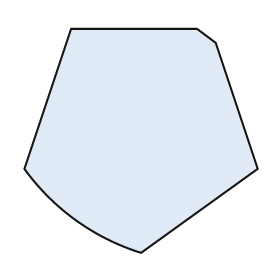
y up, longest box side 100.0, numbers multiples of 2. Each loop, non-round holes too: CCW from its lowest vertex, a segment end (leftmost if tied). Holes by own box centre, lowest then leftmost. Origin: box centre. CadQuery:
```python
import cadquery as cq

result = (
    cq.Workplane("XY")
    .moveTo(0.0, -48.0)
    .lineTo(50.0, -12.0)
    .lineTo(32.0, 42.0)
    .lineTo(24.0, 48.0)
    .lineTo(-30.0, 48.0)
    .lineTo(-50.0, -12.0)
    .threePointArc((-28.0, -34.0), (0.0, -48.0))
    .close()
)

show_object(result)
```